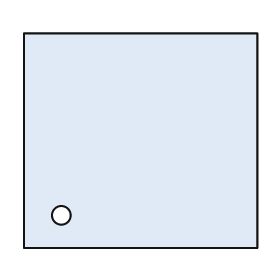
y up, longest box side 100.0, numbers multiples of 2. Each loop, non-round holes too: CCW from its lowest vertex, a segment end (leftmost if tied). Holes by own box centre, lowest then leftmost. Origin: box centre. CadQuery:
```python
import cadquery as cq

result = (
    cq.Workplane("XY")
    .moveTo(-50.0, -46.0)
    .lineTo(50.0, -46.0)
    .lineTo(50.0, 46.0)
    .lineTo(-50.0, 46.0)
    .close()
    .moveTo(-34.0, -32.0)
    .circle(4.0)
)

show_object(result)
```